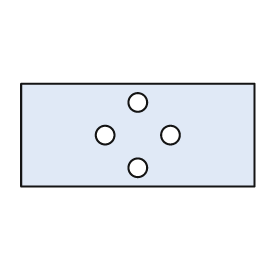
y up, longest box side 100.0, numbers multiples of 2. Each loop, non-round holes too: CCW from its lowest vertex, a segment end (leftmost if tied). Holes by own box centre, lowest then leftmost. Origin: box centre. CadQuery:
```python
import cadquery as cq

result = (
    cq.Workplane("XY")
    .moveTo(-50.0, -22.0)
    .lineTo(50.0, -22.0)
    .lineTo(50.0, 22.0)
    .lineTo(-50.0, 22.0)
    .close()
    .moveTo(0.0, -14.0)
    .circle(4.0)
    .moveTo(-14.0, 0.0)
    .circle(4.0)
    .moveTo(14.0, 0.0)
    .circle(4.0)
    .moveTo(0.0, 14.0)
    .circle(4.0)
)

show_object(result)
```